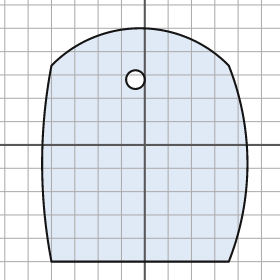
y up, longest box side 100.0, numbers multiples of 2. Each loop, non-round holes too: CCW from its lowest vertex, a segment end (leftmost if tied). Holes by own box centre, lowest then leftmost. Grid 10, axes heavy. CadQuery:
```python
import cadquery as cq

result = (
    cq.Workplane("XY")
    .moveTo(-40.0, -50.0)
    .lineTo(36.0, -50.0)
    .threePointArc((44.0, -8.0), (36.0, 34.0))
    .threePointArc((-2.0, 50.0), (-40.0, 34.0))
    .threePointArc((-44.0, -8.0), (-40.0, -50.0))
    .close()
    .moveTo(-4.0, 28.0)
    .circle(4.0)
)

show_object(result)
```